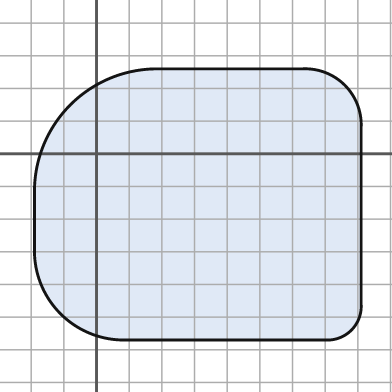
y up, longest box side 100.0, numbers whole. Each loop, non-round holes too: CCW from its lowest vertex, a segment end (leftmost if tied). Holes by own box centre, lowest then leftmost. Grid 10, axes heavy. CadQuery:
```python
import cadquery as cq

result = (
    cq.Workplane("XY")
    .moveTo(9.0, -57.0)
    .lineTo(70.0, -57.0)
    .threePointArc((78.0, -54.0), (81.0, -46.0))
    .lineTo(81.0, 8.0)
    .threePointArc((76.0, 21.0), (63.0, 26.0))
    .lineTo(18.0, 26.0)
    .threePointArc((-8.0, 15.0), (-19.0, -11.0))
    .lineTo(-19.0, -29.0)
    .threePointArc((-11.0, -49.0), (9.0, -57.0))
    .close()
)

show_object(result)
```